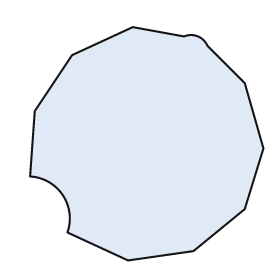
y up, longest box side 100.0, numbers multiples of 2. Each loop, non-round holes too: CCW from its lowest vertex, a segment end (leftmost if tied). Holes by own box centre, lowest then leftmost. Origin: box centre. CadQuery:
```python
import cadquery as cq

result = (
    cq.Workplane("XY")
    .moveTo(-8.0, -50.0)
    .lineTo(20.0, -46.0)
    .lineTo(42.0, -28.0)
    .lineTo(50.0, -2.0)
    .lineTo(42.0, 26.0)
    .lineTo(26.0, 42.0)
    .threePointArc((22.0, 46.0), (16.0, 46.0))
    .lineTo(-6.0, 50.0)
    .lineTo(-32.0, 38.0)
    .lineTo(-48.0, 14.0)
    .lineTo(-50.0, -14.0)
    .threePointArc((-36.0, -22.0), (-34.0, -38.0))
    .close()
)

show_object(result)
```